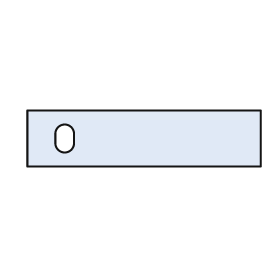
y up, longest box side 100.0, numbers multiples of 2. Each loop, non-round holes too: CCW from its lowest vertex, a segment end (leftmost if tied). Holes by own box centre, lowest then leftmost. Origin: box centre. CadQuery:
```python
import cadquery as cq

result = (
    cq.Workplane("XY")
    .moveTo(-50.0, -12.0)
    .lineTo(50.0, -12.0)
    .lineTo(50.0, 12.0)
    .lineTo(-50.0, 12.0)
    .close()
    .moveTo(-38.0, -2.0)
    .threePointArc((-34.0, -6.0), (-30.0, -2.0))
    .lineTo(-30.0, 2.0)
    .threePointArc((-34.0, 6.0), (-38.0, 2.0))
    .close()
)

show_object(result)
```